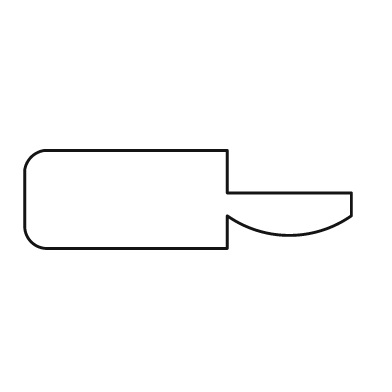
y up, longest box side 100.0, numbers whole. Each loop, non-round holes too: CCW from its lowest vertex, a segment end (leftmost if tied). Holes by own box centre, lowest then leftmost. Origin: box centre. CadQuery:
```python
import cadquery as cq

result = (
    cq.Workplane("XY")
    .moveTo(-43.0, -15.0)
    .lineTo(12.0, -15.0)
    .lineTo(12.0, -5.0)
    .threePointArc((31.0, -11.0), (50.0, -5.0))
    .lineTo(50.0, 2.0)
    .lineTo(12.0, 2.0)
    .lineTo(12.0, 15.0)
    .lineTo(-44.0, 15.0)
    .threePointArc((-48.0, 13.0), (-50.0, 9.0))
    .lineTo(-50.0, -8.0)
    .threePointArc((-48.0, -13.0), (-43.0, -15.0))
    .close()
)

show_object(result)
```